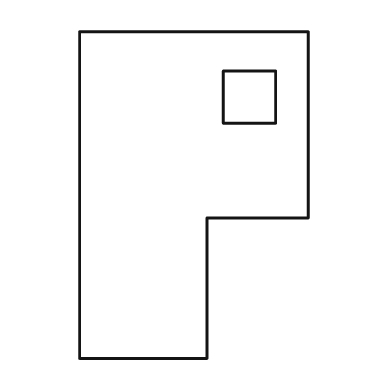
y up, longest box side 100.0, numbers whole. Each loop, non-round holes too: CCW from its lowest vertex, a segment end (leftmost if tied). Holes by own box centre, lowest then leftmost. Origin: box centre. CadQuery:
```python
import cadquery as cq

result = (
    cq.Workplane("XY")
    .moveTo(-35.0, -50.0)
    .lineTo(4.0, -50.0)
    .lineTo(4.0, -7.0)
    .lineTo(35.0, -7.0)
    .lineTo(35.0, 50.0)
    .lineTo(-35.0, 50.0)
    .close()
    .moveTo(9.0, 22.0)
    .lineTo(25.0, 22.0)
    .lineTo(25.0, 38.0)
    .lineTo(9.0, 38.0)
    .close()
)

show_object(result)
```